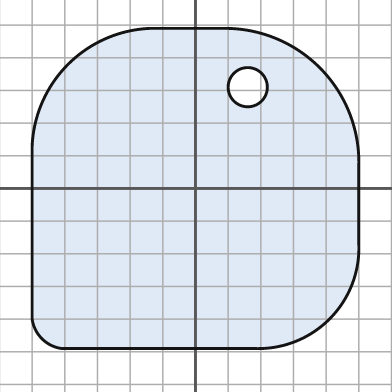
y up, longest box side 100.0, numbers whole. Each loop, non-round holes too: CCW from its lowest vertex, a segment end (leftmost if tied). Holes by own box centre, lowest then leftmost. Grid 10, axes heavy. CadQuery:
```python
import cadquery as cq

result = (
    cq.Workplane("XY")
    .moveTo(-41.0, -49.0)
    .lineTo(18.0, -49.0)
    .threePointArc((41.0, -40.0), (50.0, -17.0))
    .lineTo(50.0, 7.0)
    .threePointArc((38.0, 37.0), (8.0, 49.0))
    .lineTo(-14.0, 49.0)
    .threePointArc((-39.0, 38.0), (-50.0, 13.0))
    .lineTo(-50.0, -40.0)
    .threePointArc((-47.0, -46.0), (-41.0, -49.0))
    .close()
    .moveTo(16.0, 31.0)
    .circle(6.0)
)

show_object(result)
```